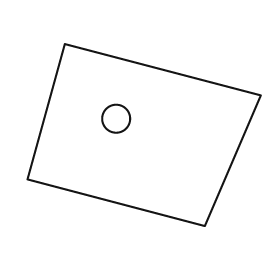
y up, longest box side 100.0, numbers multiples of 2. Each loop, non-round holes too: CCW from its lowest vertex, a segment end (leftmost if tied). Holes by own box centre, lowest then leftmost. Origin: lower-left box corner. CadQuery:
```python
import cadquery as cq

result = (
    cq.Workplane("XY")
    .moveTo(76.0, 0.0)
    .lineTo(100.0, 56.0)
    .lineTo(16.0, 78.0)
    .lineTo(0.0, 20.0)
    .close()
    .moveTo(38.0, 46.0)
    .circle(6.0)
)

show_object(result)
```